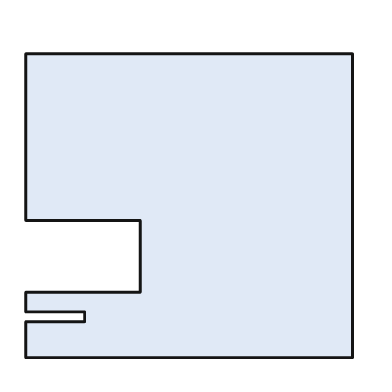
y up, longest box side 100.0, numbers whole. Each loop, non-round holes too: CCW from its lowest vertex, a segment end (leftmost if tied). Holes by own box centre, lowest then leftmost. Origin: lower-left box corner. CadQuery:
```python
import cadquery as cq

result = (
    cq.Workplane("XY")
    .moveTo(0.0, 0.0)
    .lineTo(100.0, 0.0)
    .lineTo(100.0, 93.0)
    .lineTo(0.0, 93.0)
    .lineTo(0.0, 42.0)
    .lineTo(35.0, 42.0)
    .lineTo(35.0, 20.0)
    .lineTo(0.0, 20.0)
    .lineTo(0.0, 14.0)
    .lineTo(18.0, 14.0)
    .lineTo(18.0, 11.0)
    .lineTo(0.0, 11.0)
    .close()
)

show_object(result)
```